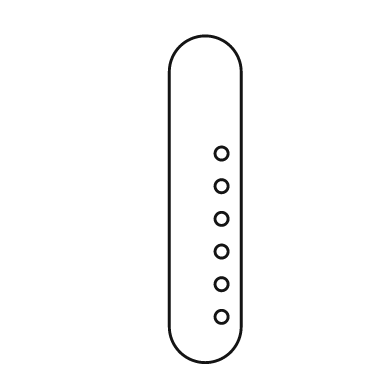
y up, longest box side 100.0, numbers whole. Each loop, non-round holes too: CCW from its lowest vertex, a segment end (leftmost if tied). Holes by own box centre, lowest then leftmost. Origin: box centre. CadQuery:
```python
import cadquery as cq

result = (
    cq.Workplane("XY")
    .moveTo(-11.0, -39.0)
    .threePointArc((0.0, -50.0), (11.0, -39.0))
    .lineTo(11.0, 39.0)
    .threePointArc((0.0, 50.0), (-11.0, 39.0))
    .close()
    .moveTo(5.0, -36.0)
    .circle(2.0)
    .moveTo(5.0, -26.0)
    .circle(2.0)
    .moveTo(5.0, -16.0)
    .circle(2.0)
    .moveTo(5.0, -6.0)
    .circle(2.0)
    .moveTo(5.0, 4.0)
    .circle(2.0)
    .moveTo(5.0, 14.0)
    .circle(2.0)
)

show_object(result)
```